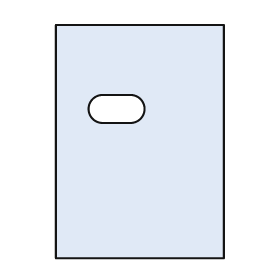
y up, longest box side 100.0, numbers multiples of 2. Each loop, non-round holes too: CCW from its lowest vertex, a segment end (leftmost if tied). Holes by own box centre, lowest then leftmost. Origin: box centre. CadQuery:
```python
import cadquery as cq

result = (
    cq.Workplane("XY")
    .moveTo(-36.0, -50.0)
    .lineTo(36.0, -50.0)
    .lineTo(36.0, 50.0)
    .lineTo(-36.0, 50.0)
    .close()
    .moveTo(-16.0, 8.0)
    .lineTo(-4.0, 8.0)
    .threePointArc((2.0, 14.0), (-4.0, 20.0))
    .lineTo(-16.0, 20.0)
    .threePointArc((-22.0, 14.0), (-16.0, 8.0))
    .close()
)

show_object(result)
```